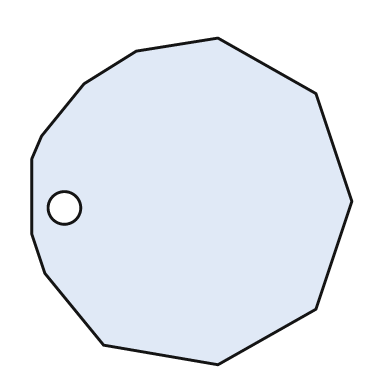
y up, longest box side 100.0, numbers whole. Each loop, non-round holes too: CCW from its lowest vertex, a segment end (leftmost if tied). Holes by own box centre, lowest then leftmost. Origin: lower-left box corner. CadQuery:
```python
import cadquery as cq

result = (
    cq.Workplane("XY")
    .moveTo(57.0, 0.0)
    .lineTo(87.0, 17.0)
    .lineTo(98.0, 50.0)
    .lineTo(87.0, 83.0)
    .lineTo(57.0, 100.0)
    .lineTo(32.0, 96.0)
    .lineTo(16.0, 86.0)
    .lineTo(3.0, 70.0)
    .lineTo(0.0, 63.0)
    .lineTo(0.0, 40.0)
    .lineTo(4.0, 28.0)
    .lineTo(22.0, 6.0)
    .close()
    .moveTo(10.0, 48.0)
    .circle(5.0)
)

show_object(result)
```